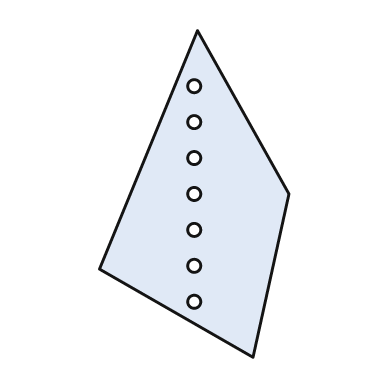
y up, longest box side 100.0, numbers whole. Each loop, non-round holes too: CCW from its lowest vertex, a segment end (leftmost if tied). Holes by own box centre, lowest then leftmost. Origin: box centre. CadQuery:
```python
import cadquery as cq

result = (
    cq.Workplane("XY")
    .moveTo(18.0, -50.0)
    .lineTo(29.0, 0.0)
    .lineTo(1.0, 50.0)
    .lineTo(-29.0, -23.0)
    .close()
    .moveTo(0.0, -33.0)
    .circle(2.0)
    .moveTo(0.0, -22.0)
    .circle(2.0)
    .moveTo(0.0, -11.0)
    .circle(2.0)
    .moveTo(0.0, 0.0)
    .circle(2.0)
    .moveTo(0.0, 11.0)
    .circle(2.0)
    .moveTo(0.0, 22.0)
    .circle(2.0)
    .moveTo(0.0, 33.0)
    .circle(2.0)
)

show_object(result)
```